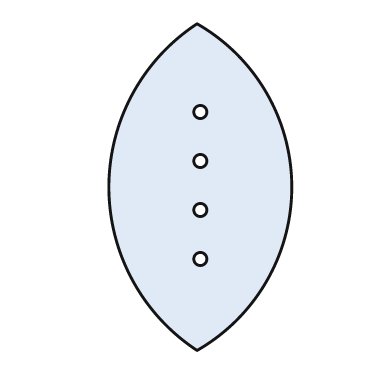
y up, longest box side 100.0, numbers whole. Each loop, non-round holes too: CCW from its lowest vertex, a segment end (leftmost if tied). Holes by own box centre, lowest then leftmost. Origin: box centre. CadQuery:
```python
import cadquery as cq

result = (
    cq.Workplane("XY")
    .moveTo(-1.0, -50.0)
    .threePointArc((28.0, 0.0), (-1.0, 50.0))
    .threePointArc((-28.0, 0.0), (-1.0, -50.0))
    .close()
    .moveTo(0.0, -22.0)
    .circle(2.0)
    .moveTo(0.0, -7.0)
    .circle(2.0)
    .moveTo(0.0, 8.0)
    .circle(2.0)
    .moveTo(0.0, 23.0)
    .circle(2.0)
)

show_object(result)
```